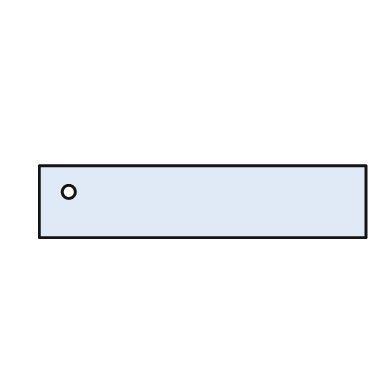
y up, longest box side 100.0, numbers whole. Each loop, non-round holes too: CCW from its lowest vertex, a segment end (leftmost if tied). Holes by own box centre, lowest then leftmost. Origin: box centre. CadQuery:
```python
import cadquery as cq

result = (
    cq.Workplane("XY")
    .moveTo(-50.0, -11.0)
    .lineTo(50.0, -11.0)
    .lineTo(50.0, 11.0)
    .lineTo(-50.0, 11.0)
    .close()
    .moveTo(-41.0, 3.0)
    .circle(2.0)
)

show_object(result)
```